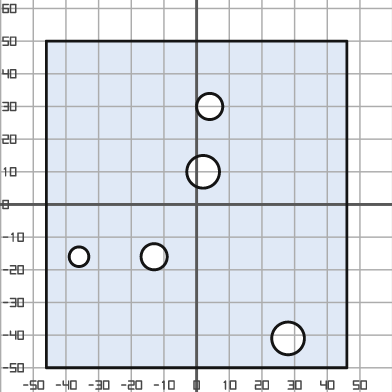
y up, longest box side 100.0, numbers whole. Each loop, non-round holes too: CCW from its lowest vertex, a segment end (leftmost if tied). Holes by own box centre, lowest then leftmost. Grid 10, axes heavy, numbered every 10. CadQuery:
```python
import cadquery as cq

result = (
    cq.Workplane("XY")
    .moveTo(-46.0, -50.0)
    .lineTo(46.0, -50.0)
    .lineTo(46.0, 50.0)
    .lineTo(-46.0, 50.0)
    .close()
    .moveTo(28.0, -41.0)
    .circle(5.0)
    .moveTo(-36.0, -16.0)
    .circle(3.0)
    .moveTo(-13.0, -16.0)
    .circle(4.0)
    .moveTo(2.0, 10.0)
    .circle(5.0)
    .moveTo(4.0, 30.0)
    .circle(4.0)
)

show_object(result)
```